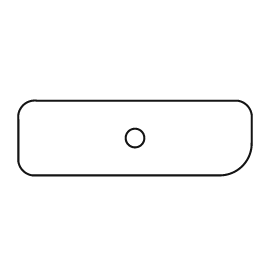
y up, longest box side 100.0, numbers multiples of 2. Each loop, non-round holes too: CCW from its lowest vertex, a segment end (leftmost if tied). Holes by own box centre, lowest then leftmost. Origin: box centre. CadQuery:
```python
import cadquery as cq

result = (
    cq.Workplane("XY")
    .moveTo(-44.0, -16.0)
    .lineTo(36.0, -16.0)
    .threePointArc((46.0, -12.0), (50.0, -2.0))
    .lineTo(50.0, 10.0)
    .threePointArc((48.0, 14.0), (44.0, 16.0))
    .lineTo(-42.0, 16.0)
    .threePointArc((-48.0, 14.0), (-50.0, 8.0))
    .lineTo(-50.0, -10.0)
    .threePointArc((-48.0, -14.0), (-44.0, -16.0))
    .close()
    .moveTo(0.0, 0.0)
    .circle(4.0)
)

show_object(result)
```